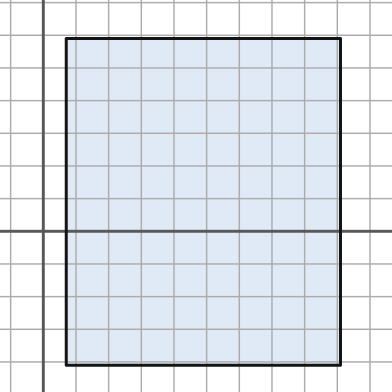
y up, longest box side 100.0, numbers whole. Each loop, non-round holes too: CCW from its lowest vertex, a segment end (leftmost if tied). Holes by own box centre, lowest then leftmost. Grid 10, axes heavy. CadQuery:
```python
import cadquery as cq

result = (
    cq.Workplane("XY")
    .moveTo(7.0, -41.0)
    .lineTo(91.0, -41.0)
    .lineTo(91.0, 59.0)
    .lineTo(7.0, 59.0)
    .close()
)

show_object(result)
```